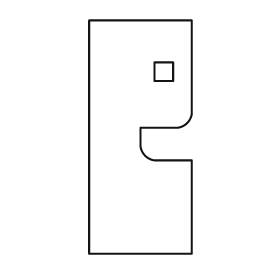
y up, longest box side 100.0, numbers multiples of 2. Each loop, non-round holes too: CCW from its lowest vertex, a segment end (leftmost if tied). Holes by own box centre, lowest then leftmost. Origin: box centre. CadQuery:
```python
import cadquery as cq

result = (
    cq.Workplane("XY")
    .moveTo(-22.0, -50.0)
    .lineTo(22.0, -50.0)
    .lineTo(22.0, -10.0)
    .lineTo(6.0, -10.0)
    .threePointArc((2.0, -8.0), (0.0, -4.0))
    .lineTo(0.0, 4.0)
    .lineTo(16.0, 4.0)
    .threePointArc((20.0, 6.0), (22.0, 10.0))
    .lineTo(22.0, 50.0)
    .lineTo(-22.0, 50.0)
    .close()
    .moveTo(6.0, 24.0)
    .lineTo(14.0, 24.0)
    .lineTo(14.0, 32.0)
    .lineTo(6.0, 32.0)
    .close()
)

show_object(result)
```